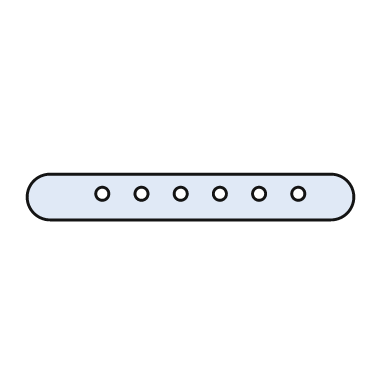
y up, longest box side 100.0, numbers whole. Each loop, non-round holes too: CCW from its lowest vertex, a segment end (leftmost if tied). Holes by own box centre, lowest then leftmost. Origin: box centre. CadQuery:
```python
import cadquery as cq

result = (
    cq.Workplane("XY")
    .moveTo(-43.0, -7.0)
    .lineTo(43.0, -7.0)
    .threePointArc((50.0, 0.0), (43.0, 7.0))
    .lineTo(-43.0, 7.0)
    .threePointArc((-50.0, 0.0), (-43.0, -7.0))
    .close()
    .moveTo(-27.0, 1.0)
    .circle(2.0)
    .moveTo(-15.0, 1.0)
    .circle(2.0)
    .moveTo(-3.0, 1.0)
    .circle(2.0)
    .moveTo(9.0, 1.0)
    .circle(2.0)
    .moveTo(21.0, 1.0)
    .circle(2.0)
    .moveTo(33.0, 1.0)
    .circle(2.0)
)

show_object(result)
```